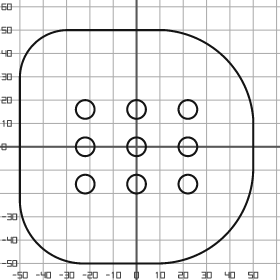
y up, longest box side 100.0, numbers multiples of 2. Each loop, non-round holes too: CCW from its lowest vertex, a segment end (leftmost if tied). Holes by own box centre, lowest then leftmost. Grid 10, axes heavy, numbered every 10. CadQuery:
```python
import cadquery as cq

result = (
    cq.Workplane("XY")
    .moveTo(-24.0, -50.0)
    .lineTo(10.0, -50.0)
    .threePointArc((38.0, -38.0), (50.0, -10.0))
    .lineTo(50.0, 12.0)
    .threePointArc((38.0, 38.0), (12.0, 50.0))
    .lineTo(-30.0, 50.0)
    .threePointArc((-44.0, 44.0), (-50.0, 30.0))
    .lineTo(-50.0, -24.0)
    .threePointArc((-42.0, -42.0), (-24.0, -50.0))
    .close()
    .moveTo(-22.0, -16.0)
    .circle(4.0)
    .moveTo(0.0, -16.0)
    .circle(4.0)
    .moveTo(22.0, -16.0)
    .circle(4.0)
    .moveTo(-22.0, 0.0)
    .circle(4.0)
    .moveTo(0.0, 0.0)
    .circle(4.0)
    .moveTo(22.0, 0.0)
    .circle(4.0)
    .moveTo(-22.0, 16.0)
    .circle(4.0)
    .moveTo(0.0, 16.0)
    .circle(4.0)
    .moveTo(22.0, 16.0)
    .circle(4.0)
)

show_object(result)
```